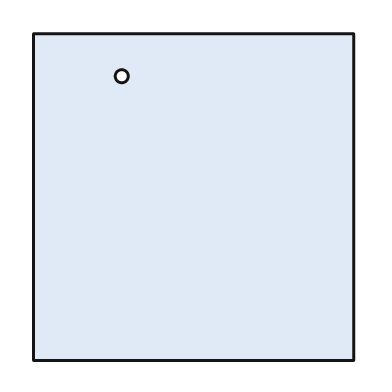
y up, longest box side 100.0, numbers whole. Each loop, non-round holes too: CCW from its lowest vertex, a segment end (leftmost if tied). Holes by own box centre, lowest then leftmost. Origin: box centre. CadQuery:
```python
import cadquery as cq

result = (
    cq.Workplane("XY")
    .moveTo(-49.0, -50.0)
    .lineTo(49.0, -50.0)
    .lineTo(49.0, 50.0)
    .lineTo(-49.0, 50.0)
    .close()
    .moveTo(-22.0, 37.0)
    .circle(2.0)
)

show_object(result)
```